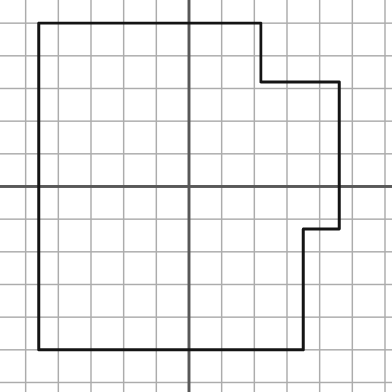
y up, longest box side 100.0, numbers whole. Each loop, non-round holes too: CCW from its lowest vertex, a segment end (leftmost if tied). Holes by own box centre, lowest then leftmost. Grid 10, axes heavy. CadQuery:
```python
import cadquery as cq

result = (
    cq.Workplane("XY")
    .moveTo(-46.0, -50.0)
    .lineTo(35.0, -50.0)
    .lineTo(35.0, -13.0)
    .lineTo(46.0, -13.0)
    .lineTo(46.0, 32.0)
    .lineTo(22.0, 32.0)
    .lineTo(22.0, 50.0)
    .lineTo(-46.0, 50.0)
    .close()
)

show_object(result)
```